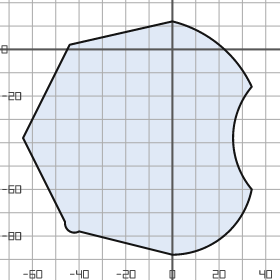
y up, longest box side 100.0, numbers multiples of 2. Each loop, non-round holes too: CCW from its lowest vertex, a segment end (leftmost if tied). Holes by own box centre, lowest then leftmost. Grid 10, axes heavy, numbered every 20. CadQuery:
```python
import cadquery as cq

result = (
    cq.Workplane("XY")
    .moveTo(0.0, -88.0)
    .threePointArc((22.0, -80.0), (34.0, -60.0))
    .threePointArc((26.0, -38.0), (34.0, -16.0))
    .threePointArc((20.0, 2.0), (0.0, 12.0))
    .lineTo(-44.0, 2.0)
    .lineTo(-64.0, -38.0)
    .lineTo(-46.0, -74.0)
    .threePointArc((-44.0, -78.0), (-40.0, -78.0))
    .close()
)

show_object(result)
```